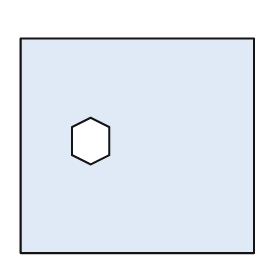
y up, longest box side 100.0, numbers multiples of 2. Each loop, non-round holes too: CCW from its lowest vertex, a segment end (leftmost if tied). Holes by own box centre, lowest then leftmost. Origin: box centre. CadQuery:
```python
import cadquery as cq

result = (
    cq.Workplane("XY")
    .moveTo(-50.0, -46.0)
    .lineTo(50.0, -46.0)
    .lineTo(50.0, 46.0)
    .lineTo(-50.0, 46.0)
    .close()
    .moveTo(-20.0, -8.0)
    .lineTo(-12.0, -4.0)
    .lineTo(-12.0, 8.0)
    .lineTo(-20.0, 12.0)
    .lineTo(-28.0, 8.0)
    .lineTo(-28.0, -4.0)
    .close()
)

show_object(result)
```